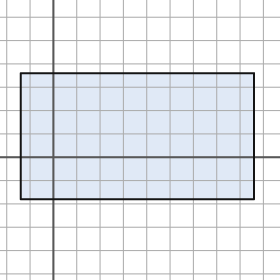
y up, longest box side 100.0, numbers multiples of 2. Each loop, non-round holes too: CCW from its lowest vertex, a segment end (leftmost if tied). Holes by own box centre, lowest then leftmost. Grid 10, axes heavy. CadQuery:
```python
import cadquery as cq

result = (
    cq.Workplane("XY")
    .moveTo(-14.0, -18.0)
    .lineTo(86.0, -18.0)
    .lineTo(86.0, 36.0)
    .lineTo(-14.0, 36.0)
    .close()
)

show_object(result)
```